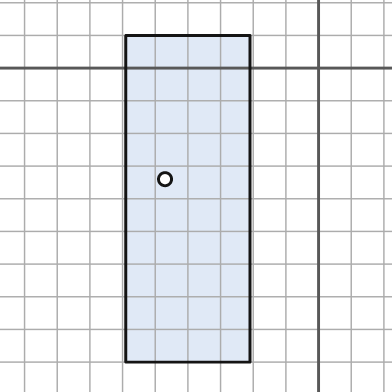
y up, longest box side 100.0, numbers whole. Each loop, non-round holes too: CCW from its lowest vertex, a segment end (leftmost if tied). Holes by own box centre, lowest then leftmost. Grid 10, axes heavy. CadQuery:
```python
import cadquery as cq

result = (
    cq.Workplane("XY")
    .moveTo(-59.0, -90.0)
    .lineTo(-21.0, -90.0)
    .lineTo(-21.0, 10.0)
    .lineTo(-59.0, 10.0)
    .close()
    .moveTo(-47.0, -34.0)
    .circle(2.0)
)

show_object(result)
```